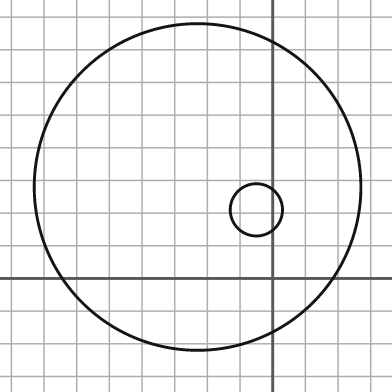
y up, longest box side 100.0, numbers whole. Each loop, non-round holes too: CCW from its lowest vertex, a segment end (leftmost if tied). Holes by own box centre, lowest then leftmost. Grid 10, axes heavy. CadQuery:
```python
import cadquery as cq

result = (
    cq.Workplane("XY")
    .moveTo(-23.0, 28.0)
    .circle(50.0)
    .moveTo(-5.0, 21.0)
    .circle(8.0)
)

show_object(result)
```